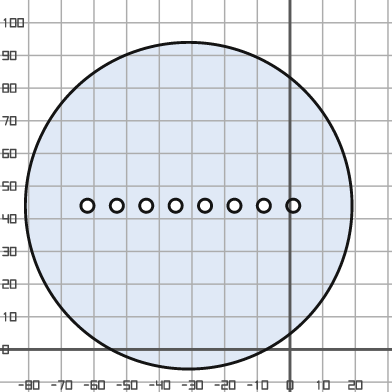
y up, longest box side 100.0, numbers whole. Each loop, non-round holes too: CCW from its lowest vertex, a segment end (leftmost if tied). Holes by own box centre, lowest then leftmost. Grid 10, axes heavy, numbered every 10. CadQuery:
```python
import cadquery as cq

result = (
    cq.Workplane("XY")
    .moveTo(-31.0, 44.0)
    .circle(50.0)
    .moveTo(-62.0, 44.0)
    .circle(2.0)
    .moveTo(-53.0, 44.0)
    .circle(2.0)
    .moveTo(-44.0, 44.0)
    .circle(2.0)
    .moveTo(-35.0, 44.0)
    .circle(2.0)
    .moveTo(-26.0, 44.0)
    .circle(2.0)
    .moveTo(-17.0, 44.0)
    .circle(2.0)
    .moveTo(-8.0, 44.0)
    .circle(2.0)
    .moveTo(1.0, 44.0)
    .circle(2.0)
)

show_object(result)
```